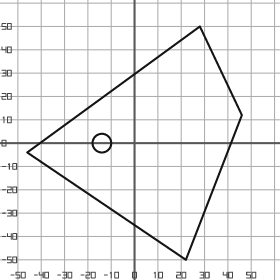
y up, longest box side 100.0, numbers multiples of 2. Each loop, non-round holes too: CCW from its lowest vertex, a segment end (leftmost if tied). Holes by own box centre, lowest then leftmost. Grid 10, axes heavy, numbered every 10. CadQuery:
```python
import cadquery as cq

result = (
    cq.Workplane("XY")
    .moveTo(22.0, -50.0)
    .lineTo(46.0, 12.0)
    .lineTo(28.0, 50.0)
    .lineTo(-46.0, -4.0)
    .close()
    .moveTo(-14.0, 0.0)
    .circle(4.0)
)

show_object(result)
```